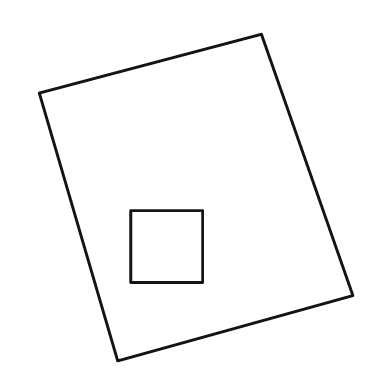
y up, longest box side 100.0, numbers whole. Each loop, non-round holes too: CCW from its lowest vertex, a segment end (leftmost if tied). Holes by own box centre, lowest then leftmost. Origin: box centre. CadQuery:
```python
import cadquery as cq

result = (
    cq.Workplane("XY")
    .moveTo(-24.0, -50.0)
    .lineTo(48.0, -30.0)
    .lineTo(20.0, 50.0)
    .lineTo(-48.0, 32.0)
    .close()
    .moveTo(-20.0, -26.0)
    .lineTo(2.0, -26.0)
    .lineTo(2.0, -4.0)
    .lineTo(-20.0, -4.0)
    .close()
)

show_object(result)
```